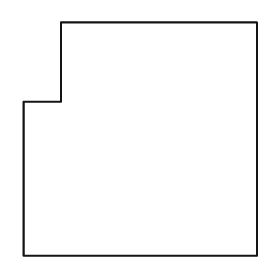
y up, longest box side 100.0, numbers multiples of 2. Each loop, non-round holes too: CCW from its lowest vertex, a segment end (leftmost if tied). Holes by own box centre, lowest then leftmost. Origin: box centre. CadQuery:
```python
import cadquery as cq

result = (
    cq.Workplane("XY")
    .moveTo(-50.0, -50.0)
    .lineTo(50.0, -50.0)
    .lineTo(50.0, 50.0)
    .lineTo(-34.0, 50.0)
    .lineTo(-34.0, 16.0)
    .lineTo(-50.0, 16.0)
    .close()
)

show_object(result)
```